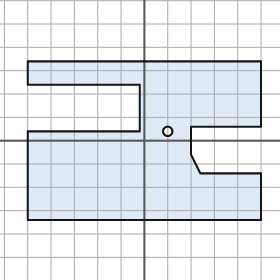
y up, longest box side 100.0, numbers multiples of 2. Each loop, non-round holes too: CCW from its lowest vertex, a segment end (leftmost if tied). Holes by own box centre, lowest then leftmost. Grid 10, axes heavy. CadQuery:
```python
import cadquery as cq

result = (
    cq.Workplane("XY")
    .moveTo(-50.0, -34.0)
    .lineTo(50.0, -34.0)
    .lineTo(50.0, -14.0)
    .lineTo(24.0, -14.0)
    .lineTo(20.0, -6.0)
    .lineTo(20.0, 6.0)
    .lineTo(50.0, 6.0)
    .lineTo(50.0, 34.0)
    .lineTo(-50.0, 34.0)
    .lineTo(-50.0, 24.0)
    .lineTo(-2.0, 24.0)
    .lineTo(-2.0, 4.0)
    .lineTo(-50.0, 4.0)
    .close()
    .moveTo(10.0, 4.0)
    .circle(2.0)
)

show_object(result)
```